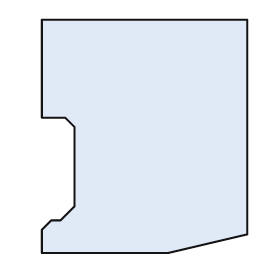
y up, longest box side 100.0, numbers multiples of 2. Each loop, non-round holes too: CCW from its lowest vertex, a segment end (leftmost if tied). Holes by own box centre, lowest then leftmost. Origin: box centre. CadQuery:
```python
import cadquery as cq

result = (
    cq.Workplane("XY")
    .moveTo(-44.0, -50.0)
    .lineTo(10.0, -50.0)
    .lineTo(44.0, -42.0)
    .lineTo(44.0, 50.0)
    .lineTo(-44.0, 50.0)
    .lineTo(-44.0, 8.0)
    .lineTo(-34.0, 8.0)
    .lineTo(-30.0, 4.0)
    .lineTo(-30.0, -30.0)
    .lineTo(-36.0, -36.0)
    .lineTo(-40.0, -36.0)
    .lineTo(-44.0, -40.0)
    .close()
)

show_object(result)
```